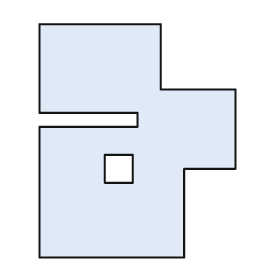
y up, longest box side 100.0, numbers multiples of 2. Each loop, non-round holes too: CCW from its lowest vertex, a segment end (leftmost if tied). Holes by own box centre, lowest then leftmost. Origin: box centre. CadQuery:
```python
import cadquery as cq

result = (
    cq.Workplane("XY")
    .moveTo(-42.0, -50.0)
    .lineTo(20.0, -50.0)
    .lineTo(20.0, -12.0)
    .lineTo(42.0, -12.0)
    .lineTo(42.0, 22.0)
    .lineTo(10.0, 22.0)
    .lineTo(10.0, 50.0)
    .lineTo(-42.0, 50.0)
    .lineTo(-42.0, 12.0)
    .lineTo(0.0, 12.0)
    .lineTo(0.0, 6.0)
    .lineTo(-42.0, 6.0)
    .close()
    .moveTo(-14.0, -18.0)
    .lineTo(-2.0, -18.0)
    .lineTo(-2.0, -6.0)
    .lineTo(-14.0, -6.0)
    .close()
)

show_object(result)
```